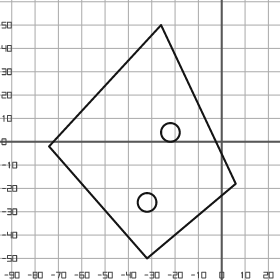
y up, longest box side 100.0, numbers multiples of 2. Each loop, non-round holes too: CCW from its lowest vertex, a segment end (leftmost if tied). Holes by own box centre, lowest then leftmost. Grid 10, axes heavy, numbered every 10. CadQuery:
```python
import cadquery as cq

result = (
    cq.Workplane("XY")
    .moveTo(-32.0, -50.0)
    .lineTo(6.0, -18.0)
    .lineTo(-26.0, 50.0)
    .lineTo(-74.0, -2.0)
    .close()
    .moveTo(-32.0, -26.0)
    .circle(4.0)
    .moveTo(-22.0, 4.0)
    .circle(4.0)
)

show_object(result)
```